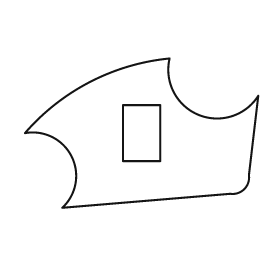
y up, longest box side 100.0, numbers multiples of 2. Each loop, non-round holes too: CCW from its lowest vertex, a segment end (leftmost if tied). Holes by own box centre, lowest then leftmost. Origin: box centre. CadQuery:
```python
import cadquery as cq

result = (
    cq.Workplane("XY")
    .moveTo(-34.0, -32.0)
    .lineTo(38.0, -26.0)
    .threePointArc((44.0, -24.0), (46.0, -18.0))
    .lineTo(50.0, 16.0)
    .threePointArc((24.0, 8.0), (12.0, 32.0))
    .threePointArc((-22.0, 22.0), (-50.0, 0.0))
    .threePointArc((-30.0, -10.0), (-34.0, -32.0))
    .close()
    .moveTo(-8.0, -12.0)
    .lineTo(8.0, -12.0)
    .lineTo(8.0, 12.0)
    .lineTo(-8.0, 12.0)
    .close()
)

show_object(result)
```